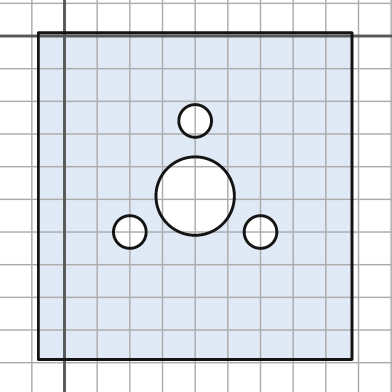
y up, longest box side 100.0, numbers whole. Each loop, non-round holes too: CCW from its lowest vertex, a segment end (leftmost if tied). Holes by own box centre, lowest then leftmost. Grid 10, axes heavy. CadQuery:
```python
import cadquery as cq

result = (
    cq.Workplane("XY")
    .moveTo(-8.0, -99.0)
    .lineTo(88.0, -99.0)
    .lineTo(88.0, 1.0)
    .lineTo(-8.0, 1.0)
    .close()
    .moveTo(20.0, -60.0)
    .circle(5.0)
    .moveTo(60.0, -60.0)
    .circle(5.0)
    .moveTo(40.0, -49.0)
    .circle(12.0)
    .moveTo(40.0, -26.0)
    .circle(5.0)
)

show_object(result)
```